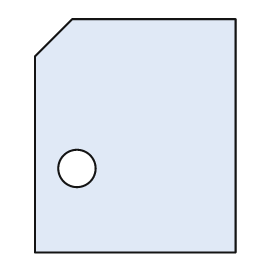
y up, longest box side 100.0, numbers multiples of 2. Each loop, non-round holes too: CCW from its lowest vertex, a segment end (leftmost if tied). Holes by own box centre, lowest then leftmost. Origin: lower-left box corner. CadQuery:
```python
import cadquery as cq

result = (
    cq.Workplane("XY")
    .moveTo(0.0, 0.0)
    .lineTo(86.0, 0.0)
    .lineTo(86.0, 100.0)
    .lineTo(16.0, 100.0)
    .lineTo(0.0, 84.0)
    .close()
    .moveTo(18.0, 36.0)
    .circle(8.0)
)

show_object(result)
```